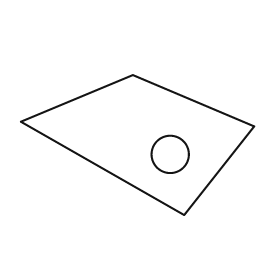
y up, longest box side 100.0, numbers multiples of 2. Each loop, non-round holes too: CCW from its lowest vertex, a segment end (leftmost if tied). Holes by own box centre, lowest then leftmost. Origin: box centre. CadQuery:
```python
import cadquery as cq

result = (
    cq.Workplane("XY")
    .moveTo(20.0, -30.0)
    .lineTo(50.0, 8.0)
    .lineTo(-2.0, 30.0)
    .lineTo(-50.0, 10.0)
    .close()
    .moveTo(14.0, -4.0)
    .circle(8.0)
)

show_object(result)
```